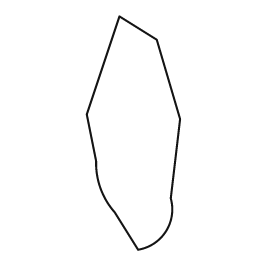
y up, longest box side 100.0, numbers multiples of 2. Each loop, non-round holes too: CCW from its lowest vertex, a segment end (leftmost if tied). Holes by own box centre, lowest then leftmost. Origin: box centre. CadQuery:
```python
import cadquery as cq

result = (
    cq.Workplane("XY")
    .moveTo(2.0, -50.0)
    .threePointArc((14.0, -42.0), (16.0, -28.0))
    .lineTo(20.0, 6.0)
    .lineTo(10.0, 40.0)
    .lineTo(-6.0, 50.0)
    .lineTo(-20.0, 8.0)
    .lineTo(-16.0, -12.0)
    .threePointArc((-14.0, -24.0), (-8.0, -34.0))
    .close()
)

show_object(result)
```